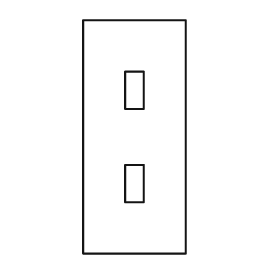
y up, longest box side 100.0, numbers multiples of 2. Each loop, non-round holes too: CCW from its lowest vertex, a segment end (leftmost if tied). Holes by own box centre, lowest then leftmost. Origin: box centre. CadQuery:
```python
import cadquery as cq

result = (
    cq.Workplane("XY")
    .moveTo(-22.0, -50.0)
    .lineTo(22.0, -50.0)
    .lineTo(22.0, 50.0)
    .lineTo(-22.0, 50.0)
    .close()
    .moveTo(-4.0, -28.0)
    .lineTo(4.0, -28.0)
    .lineTo(4.0, -12.0)
    .lineTo(-4.0, -12.0)
    .close()
    .moveTo(-4.0, 12.0)
    .lineTo(4.0, 12.0)
    .lineTo(4.0, 28.0)
    .lineTo(-4.0, 28.0)
    .close()
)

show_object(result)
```